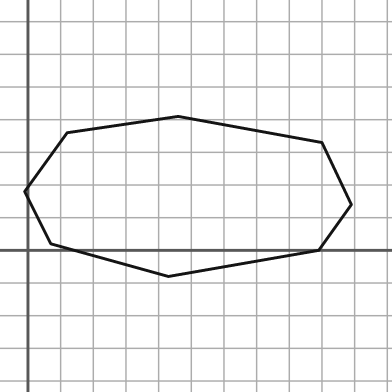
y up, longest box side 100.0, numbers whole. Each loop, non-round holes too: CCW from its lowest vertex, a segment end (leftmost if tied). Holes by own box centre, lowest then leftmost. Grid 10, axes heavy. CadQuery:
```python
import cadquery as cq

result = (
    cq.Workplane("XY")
    .moveTo(43.0, -8.0)
    .lineTo(89.0, 0.0)
    .lineTo(99.0, 14.0)
    .lineTo(90.0, 33.0)
    .lineTo(46.0, 41.0)
    .lineTo(12.0, 36.0)
    .lineTo(-1.0, 18.0)
    .lineTo(7.0, 2.0)
    .close()
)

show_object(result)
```